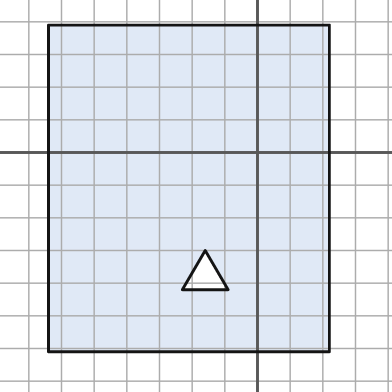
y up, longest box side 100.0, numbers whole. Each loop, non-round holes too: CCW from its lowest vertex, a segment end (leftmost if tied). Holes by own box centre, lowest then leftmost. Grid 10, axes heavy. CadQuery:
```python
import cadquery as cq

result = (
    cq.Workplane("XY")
    .moveTo(-64.0, -61.0)
    .lineTo(22.0, -61.0)
    .lineTo(22.0, 39.0)
    .lineTo(-64.0, 39.0)
    .close()
    .moveTo(-23.0, -42.0)
    .lineTo(-9.0, -42.0)
    .lineTo(-16.0, -30.0)
    .close()
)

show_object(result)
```